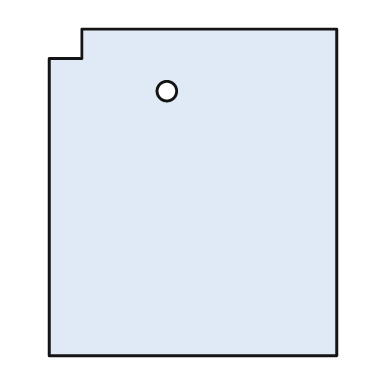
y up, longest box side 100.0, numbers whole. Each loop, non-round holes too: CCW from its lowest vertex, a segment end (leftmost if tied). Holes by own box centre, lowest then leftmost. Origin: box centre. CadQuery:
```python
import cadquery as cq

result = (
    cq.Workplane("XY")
    .moveTo(-44.0, -50.0)
    .lineTo(44.0, -50.0)
    .lineTo(44.0, 50.0)
    .lineTo(-34.0, 50.0)
    .lineTo(-34.0, 41.0)
    .lineTo(-44.0, 41.0)
    .close()
    .moveTo(-8.0, 31.0)
    .circle(3.0)
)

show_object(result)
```